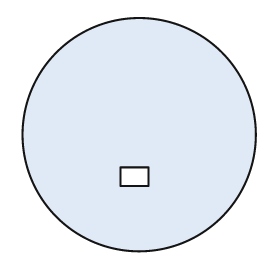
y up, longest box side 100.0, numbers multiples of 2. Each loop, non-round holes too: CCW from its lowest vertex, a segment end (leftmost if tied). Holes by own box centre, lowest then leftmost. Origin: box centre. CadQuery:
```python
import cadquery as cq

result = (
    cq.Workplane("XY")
    .moveTo(0.0, 0.0)
    .circle(50.0)
    .moveTo(-8.0, -22.0)
    .lineTo(4.0, -22.0)
    .lineTo(4.0, -14.0)
    .lineTo(-8.0, -14.0)
    .close()
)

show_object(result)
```